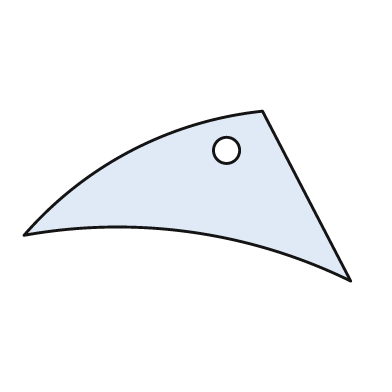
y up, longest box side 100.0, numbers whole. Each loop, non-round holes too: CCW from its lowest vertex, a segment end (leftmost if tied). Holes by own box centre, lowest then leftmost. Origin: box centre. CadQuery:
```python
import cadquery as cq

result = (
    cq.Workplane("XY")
    .moveTo(50.0, -26.0)
    .lineTo(23.0, 26.0)
    .threePointArc((-17.0, 14.0), (-50.0, -12.0))
    .threePointArc((1.0, -11.0), (50.0, -26.0))
    .close()
    .moveTo(12.0, 14.0)
    .circle(4.0)
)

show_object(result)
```